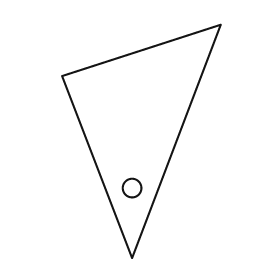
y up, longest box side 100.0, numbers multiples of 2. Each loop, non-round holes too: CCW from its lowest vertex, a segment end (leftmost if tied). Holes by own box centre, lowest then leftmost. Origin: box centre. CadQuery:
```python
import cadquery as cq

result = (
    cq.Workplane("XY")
    .moveTo(-4.0, -50.0)
    .lineTo(34.0, 50.0)
    .lineTo(-34.0, 28.0)
    .close()
    .moveTo(-4.0, -20.0)
    .circle(4.0)
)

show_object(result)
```